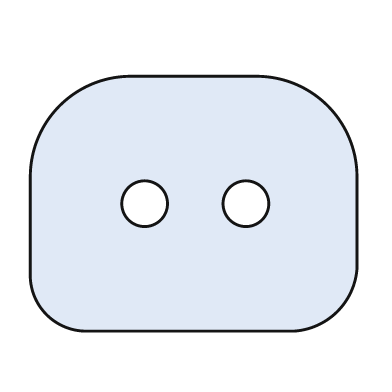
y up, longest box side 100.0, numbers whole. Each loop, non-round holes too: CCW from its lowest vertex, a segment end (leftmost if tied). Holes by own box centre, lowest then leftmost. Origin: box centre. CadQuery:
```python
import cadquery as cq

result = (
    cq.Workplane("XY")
    .moveTo(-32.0, -39.0)
    .lineTo(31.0, -39.0)
    .threePointArc((44.0, -33.0), (50.0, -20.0))
    .lineTo(50.0, 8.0)
    .threePointArc((41.0, 30.0), (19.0, 39.0))
    .lineTo(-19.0, 39.0)
    .threePointArc((-41.0, 30.0), (-50.0, 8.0))
    .lineTo(-50.0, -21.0)
    .threePointArc((-45.0, -34.0), (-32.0, -39.0))
    .close()
    .moveTo(-15.0, 0.0)
    .circle(7.0)
    .moveTo(16.0, 0.0)
    .circle(7.0)
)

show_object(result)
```